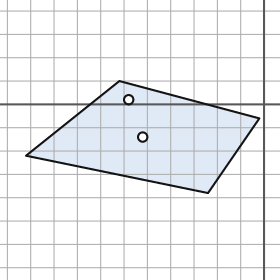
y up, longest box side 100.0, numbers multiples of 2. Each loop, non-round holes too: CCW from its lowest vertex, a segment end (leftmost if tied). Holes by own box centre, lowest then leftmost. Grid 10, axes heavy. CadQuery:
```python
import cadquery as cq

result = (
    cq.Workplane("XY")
    .moveTo(-24.0, -38.0)
    .lineTo(-2.0, -6.0)
    .lineTo(-62.0, 10.0)
    .lineTo(-102.0, -22.0)
    .close()
    .moveTo(-52.0, -14.0)
    .circle(2.0)
    .moveTo(-58.0, 2.0)
    .circle(2.0)
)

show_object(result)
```